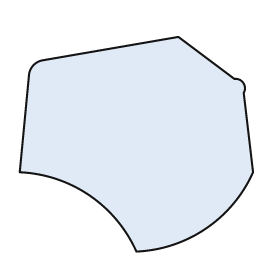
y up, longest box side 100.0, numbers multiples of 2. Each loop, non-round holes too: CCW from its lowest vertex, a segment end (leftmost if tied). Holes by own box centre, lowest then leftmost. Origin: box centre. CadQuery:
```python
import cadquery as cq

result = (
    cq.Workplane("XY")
    .moveTo(0.0, -46.0)
    .threePointArc((30.0, -36.0), (50.0, -12.0))
    .lineTo(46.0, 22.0)
    .threePointArc((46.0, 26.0), (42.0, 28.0))
    .lineTo(18.0, 46.0)
    .lineTo(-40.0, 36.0)
    .threePointArc((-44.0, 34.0), (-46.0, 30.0))
    .lineTo(-50.0, -12.0)
    .threePointArc((-20.0, -22.0), (0.0, -46.0))
    .close()
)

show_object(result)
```